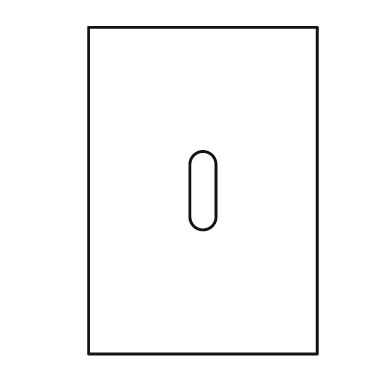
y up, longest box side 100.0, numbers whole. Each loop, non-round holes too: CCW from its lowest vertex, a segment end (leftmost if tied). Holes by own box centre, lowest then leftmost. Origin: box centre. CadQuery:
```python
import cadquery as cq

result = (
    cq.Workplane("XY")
    .moveTo(-35.0, -50.0)
    .lineTo(35.0, -50.0)
    .lineTo(35.0, 50.0)
    .lineTo(-35.0, 50.0)
    .close()
    .moveTo(-4.0, -8.0)
    .threePointArc((0.0, -12.0), (4.0, -8.0))
    .lineTo(4.0, 8.0)
    .threePointArc((0.0, 12.0), (-4.0, 8.0))
    .close()
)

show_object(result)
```